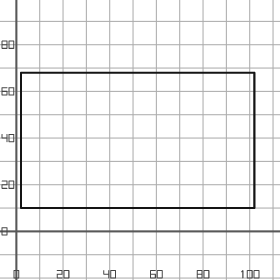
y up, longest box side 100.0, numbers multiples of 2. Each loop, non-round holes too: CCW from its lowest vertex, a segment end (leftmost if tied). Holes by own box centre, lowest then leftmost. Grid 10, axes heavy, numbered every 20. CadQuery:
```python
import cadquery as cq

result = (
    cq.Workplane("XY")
    .moveTo(2.0, 10.0)
    .lineTo(102.0, 10.0)
    .lineTo(102.0, 68.0)
    .lineTo(2.0, 68.0)
    .close()
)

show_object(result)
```